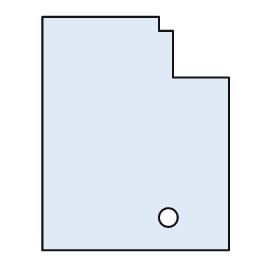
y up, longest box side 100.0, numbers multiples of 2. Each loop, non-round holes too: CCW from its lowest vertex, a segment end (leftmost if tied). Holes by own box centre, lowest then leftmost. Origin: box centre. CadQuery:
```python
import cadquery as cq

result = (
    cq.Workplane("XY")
    .moveTo(-40.0, -50.0)
    .lineTo(40.0, -50.0)
    .lineTo(40.0, 24.0)
    .lineTo(16.0, 24.0)
    .lineTo(16.0, 44.0)
    .lineTo(10.0, 44.0)
    .lineTo(10.0, 50.0)
    .lineTo(-40.0, 50.0)
    .close()
    .moveTo(14.0, -36.0)
    .circle(4.0)
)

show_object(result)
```